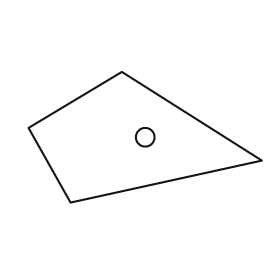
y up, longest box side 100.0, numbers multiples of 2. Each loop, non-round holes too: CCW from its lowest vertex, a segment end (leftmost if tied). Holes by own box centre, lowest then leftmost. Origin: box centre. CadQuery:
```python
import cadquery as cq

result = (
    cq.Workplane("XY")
    .moveTo(-32.0, -28.0)
    .lineTo(50.0, -10.0)
    .lineTo(-10.0, 28.0)
    .lineTo(-50.0, 4.0)
    .close()
    .moveTo(0.0, 0.0)
    .circle(4.0)
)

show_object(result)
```